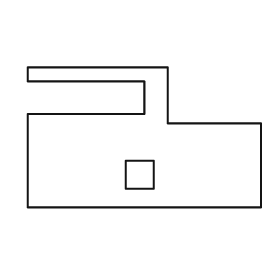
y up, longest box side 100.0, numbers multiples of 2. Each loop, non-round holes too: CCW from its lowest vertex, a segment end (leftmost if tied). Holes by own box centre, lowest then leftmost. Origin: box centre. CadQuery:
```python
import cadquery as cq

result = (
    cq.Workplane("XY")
    .moveTo(-50.0, -30.0)
    .lineTo(50.0, -30.0)
    .lineTo(50.0, 6.0)
    .lineTo(10.0, 6.0)
    .lineTo(10.0, 30.0)
    .lineTo(-50.0, 30.0)
    .lineTo(-50.0, 24.0)
    .lineTo(0.0, 24.0)
    .lineTo(0.0, 10.0)
    .lineTo(-50.0, 10.0)
    .close()
    .moveTo(-8.0, -22.0)
    .lineTo(4.0, -22.0)
    .lineTo(4.0, -10.0)
    .lineTo(-8.0, -10.0)
    .close()
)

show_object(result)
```